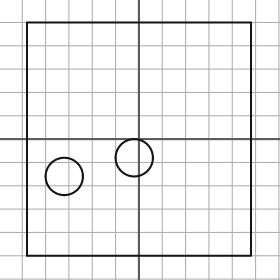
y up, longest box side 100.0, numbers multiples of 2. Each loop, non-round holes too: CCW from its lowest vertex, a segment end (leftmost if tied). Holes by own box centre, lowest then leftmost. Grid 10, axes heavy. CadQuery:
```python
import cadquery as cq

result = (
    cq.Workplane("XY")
    .moveTo(-48.0, -50.0)
    .lineTo(48.0, -50.0)
    .lineTo(48.0, 50.0)
    .lineTo(-48.0, 50.0)
    .close()
    .moveTo(-32.0, -16.0)
    .circle(8.0)
    .moveTo(-2.0, -8.0)
    .circle(8.0)
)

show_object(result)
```